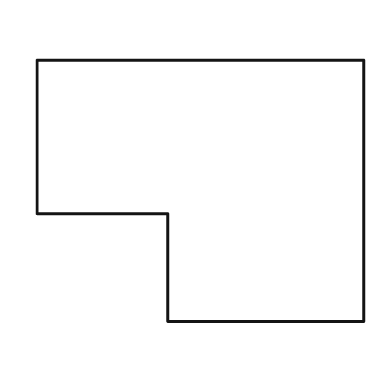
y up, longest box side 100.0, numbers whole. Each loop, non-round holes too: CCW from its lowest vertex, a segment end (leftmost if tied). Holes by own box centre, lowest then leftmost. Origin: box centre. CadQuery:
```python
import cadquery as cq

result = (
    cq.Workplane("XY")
    .moveTo(-10.0, -40.0)
    .lineTo(50.0, -40.0)
    .lineTo(50.0, 40.0)
    .lineTo(-50.0, 40.0)
    .lineTo(-50.0, -7.0)
    .lineTo(-10.0, -7.0)
    .close()
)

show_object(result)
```